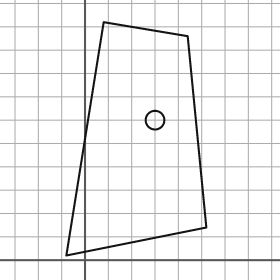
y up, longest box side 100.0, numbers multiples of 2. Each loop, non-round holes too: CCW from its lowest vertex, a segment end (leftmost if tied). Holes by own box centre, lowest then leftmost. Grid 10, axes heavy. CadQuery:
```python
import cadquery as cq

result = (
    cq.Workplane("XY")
    .moveTo(-8.0, 2.0)
    .lineTo(52.0, 14.0)
    .lineTo(44.0, 96.0)
    .lineTo(8.0, 102.0)
    .close()
    .moveTo(30.0, 60.0)
    .circle(4.0)
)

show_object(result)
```